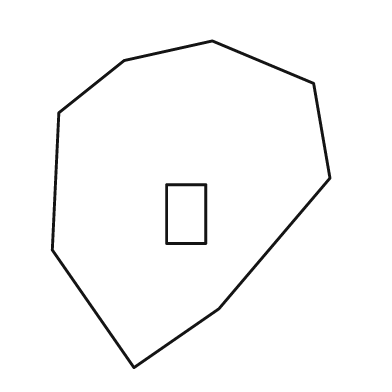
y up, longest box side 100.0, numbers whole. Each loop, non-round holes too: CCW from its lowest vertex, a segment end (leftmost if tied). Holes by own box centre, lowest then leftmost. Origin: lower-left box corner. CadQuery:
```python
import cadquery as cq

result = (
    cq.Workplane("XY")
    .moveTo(25.0, 0.0)
    .lineTo(51.0, 18.0)
    .lineTo(85.0, 58.0)
    .lineTo(80.0, 87.0)
    .lineTo(49.0, 100.0)
    .lineTo(22.0, 94.0)
    .lineTo(2.0, 78.0)
    .lineTo(0.0, 36.0)
    .close()
    .moveTo(35.0, 38.0)
    .lineTo(47.0, 38.0)
    .lineTo(47.0, 56.0)
    .lineTo(35.0, 56.0)
    .close()
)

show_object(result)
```